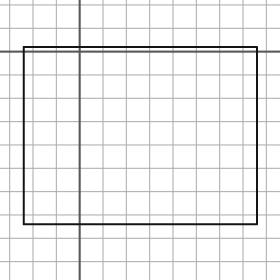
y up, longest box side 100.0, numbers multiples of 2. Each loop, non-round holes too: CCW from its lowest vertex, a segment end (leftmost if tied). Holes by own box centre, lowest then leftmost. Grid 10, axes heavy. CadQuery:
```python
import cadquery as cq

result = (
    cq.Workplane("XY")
    .moveTo(-24.0, -74.0)
    .lineTo(76.0, -74.0)
    .lineTo(76.0, 2.0)
    .lineTo(-24.0, 2.0)
    .close()
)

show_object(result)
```